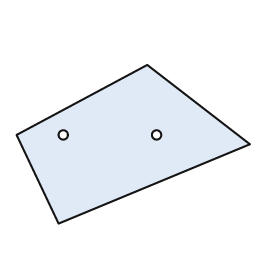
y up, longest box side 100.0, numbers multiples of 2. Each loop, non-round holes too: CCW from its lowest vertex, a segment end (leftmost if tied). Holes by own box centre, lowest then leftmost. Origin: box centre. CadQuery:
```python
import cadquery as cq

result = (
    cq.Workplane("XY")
    .moveTo(-32.0, -34.0)
    .lineTo(50.0, 0.0)
    .lineTo(6.0, 34.0)
    .lineTo(-50.0, 4.0)
    .close()
    .moveTo(-30.0, 4.0)
    .circle(2.0)
    .moveTo(10.0, 4.0)
    .circle(2.0)
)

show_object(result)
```